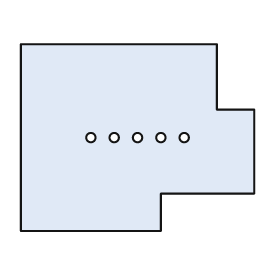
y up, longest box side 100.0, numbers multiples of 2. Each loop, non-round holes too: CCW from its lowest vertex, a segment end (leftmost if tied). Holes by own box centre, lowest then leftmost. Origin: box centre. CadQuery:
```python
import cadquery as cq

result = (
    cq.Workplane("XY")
    .moveTo(-50.0, -40.0)
    .lineTo(10.0, -40.0)
    .lineTo(10.0, -24.0)
    .lineTo(50.0, -24.0)
    .lineTo(50.0, 12.0)
    .lineTo(34.0, 12.0)
    .lineTo(34.0, 40.0)
    .lineTo(-50.0, 40.0)
    .close()
    .moveTo(-20.0, 0.0)
    .circle(2.0)
    .moveTo(-10.0, 0.0)
    .circle(2.0)
    .moveTo(0.0, 0.0)
    .circle(2.0)
    .moveTo(10.0, 0.0)
    .circle(2.0)
    .moveTo(20.0, 0.0)
    .circle(2.0)
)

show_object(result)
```